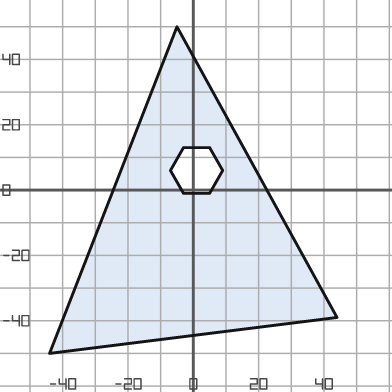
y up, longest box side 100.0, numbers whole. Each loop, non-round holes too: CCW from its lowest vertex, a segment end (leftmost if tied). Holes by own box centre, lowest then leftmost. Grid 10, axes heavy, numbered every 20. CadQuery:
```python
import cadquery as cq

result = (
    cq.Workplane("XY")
    .moveTo(-44.0, -50.0)
    .lineTo(44.0, -39.0)
    .lineTo(-5.0, 50.0)
    .close()
    .moveTo(-3.0, -1.0)
    .lineTo(5.0, -1.0)
    .lineTo(9.0, 6.0)
    .lineTo(5.0, 13.0)
    .lineTo(-3.0, 13.0)
    .lineTo(-7.0, 6.0)
    .close()
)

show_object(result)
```